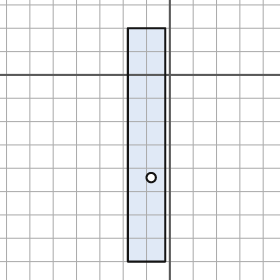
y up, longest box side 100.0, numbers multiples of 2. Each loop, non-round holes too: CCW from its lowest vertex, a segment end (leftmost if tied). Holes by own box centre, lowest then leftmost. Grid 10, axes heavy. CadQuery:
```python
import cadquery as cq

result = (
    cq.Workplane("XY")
    .moveTo(-18.0, -80.0)
    .lineTo(-2.0, -80.0)
    .lineTo(-2.0, 20.0)
    .lineTo(-18.0, 20.0)
    .close()
    .moveTo(-8.0, -44.0)
    .circle(2.0)
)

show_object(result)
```